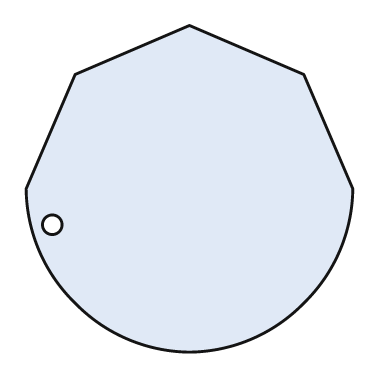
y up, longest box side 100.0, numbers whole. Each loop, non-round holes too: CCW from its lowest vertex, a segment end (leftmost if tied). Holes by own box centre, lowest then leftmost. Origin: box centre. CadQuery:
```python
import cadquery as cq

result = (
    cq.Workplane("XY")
    .moveTo(0.0, -50.0)
    .threePointArc((19.0, -46.0), (35.0, -35.0))
    .threePointArc((46.0, -19.0), (50.0, 0.0))
    .lineTo(35.0, 35.0)
    .lineTo(0.0, 50.0)
    .lineTo(-35.0, 35.0)
    .lineTo(-50.0, 0.0)
    .threePointArc((-46.0, -19.0), (-35.0, -35.0))
    .threePointArc((-19.0, -46.0), (0.0, -50.0))
    .close()
    .moveTo(-42.0, -11.0)
    .circle(3.0)
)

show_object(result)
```